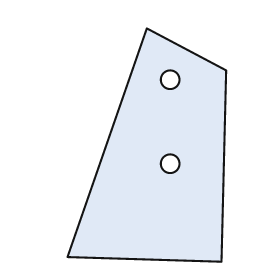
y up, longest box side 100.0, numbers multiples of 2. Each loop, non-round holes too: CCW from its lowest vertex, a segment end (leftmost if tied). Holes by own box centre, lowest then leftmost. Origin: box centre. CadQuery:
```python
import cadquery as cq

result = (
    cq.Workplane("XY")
    .moveTo(32.0, -50.0)
    .lineTo(34.0, 32.0)
    .lineTo(0.0, 50.0)
    .lineTo(-34.0, -48.0)
    .close()
    .moveTo(10.0, -8.0)
    .circle(4.0)
    .moveTo(10.0, 28.0)
    .circle(4.0)
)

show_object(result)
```